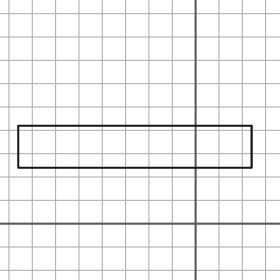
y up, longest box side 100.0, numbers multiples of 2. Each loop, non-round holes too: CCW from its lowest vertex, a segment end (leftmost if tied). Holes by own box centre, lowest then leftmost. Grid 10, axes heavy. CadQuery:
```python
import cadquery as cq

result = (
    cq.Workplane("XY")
    .moveTo(-76.0, 24.0)
    .lineTo(24.0, 24.0)
    .lineTo(24.0, 42.0)
    .lineTo(-76.0, 42.0)
    .close()
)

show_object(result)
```